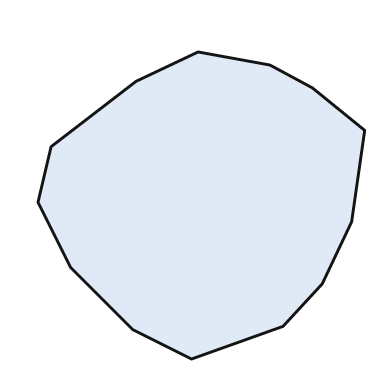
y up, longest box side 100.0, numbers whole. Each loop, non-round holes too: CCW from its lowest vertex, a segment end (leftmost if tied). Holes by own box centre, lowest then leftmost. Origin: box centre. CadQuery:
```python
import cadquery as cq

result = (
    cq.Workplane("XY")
    .moveTo(-3.0, -47.0)
    .lineTo(25.0, -37.0)
    .lineTo(37.0, -24.0)
    .lineTo(46.0, -5.0)
    .lineTo(50.0, 23.0)
    .lineTo(34.0, 36.0)
    .lineTo(21.0, 43.0)
    .lineTo(-1.0, 47.0)
    .lineTo(-20.0, 38.0)
    .lineTo(-46.0, 18.0)
    .lineTo(-50.0, 1.0)
    .lineTo(-40.0, -19.0)
    .lineTo(-21.0, -38.0)
    .close()
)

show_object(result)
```